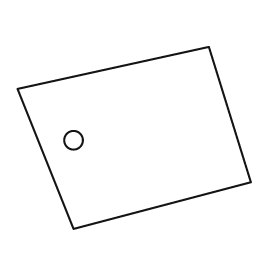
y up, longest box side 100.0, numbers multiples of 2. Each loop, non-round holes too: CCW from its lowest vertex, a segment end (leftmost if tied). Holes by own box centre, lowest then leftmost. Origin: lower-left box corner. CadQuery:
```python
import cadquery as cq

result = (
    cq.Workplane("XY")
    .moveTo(24.0, 0.0)
    .lineTo(100.0, 20.0)
    .lineTo(82.0, 78.0)
    .lineTo(0.0, 60.0)
    .close()
    .moveTo(24.0, 38.0)
    .circle(4.0)
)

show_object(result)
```